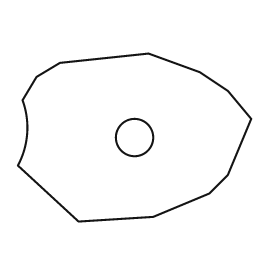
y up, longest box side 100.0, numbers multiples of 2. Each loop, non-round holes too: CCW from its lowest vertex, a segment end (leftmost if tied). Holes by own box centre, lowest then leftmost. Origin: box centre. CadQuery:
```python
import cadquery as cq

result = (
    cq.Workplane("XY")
    .moveTo(-24.0, -36.0)
    .lineTo(8.0, -34.0)
    .lineTo(32.0, -24.0)
    .lineTo(40.0, -16.0)
    .lineTo(50.0, 8.0)
    .lineTo(40.0, 20.0)
    .lineTo(28.0, 28.0)
    .lineTo(6.0, 36.0)
    .lineTo(-32.0, 32.0)
    .lineTo(-42.0, 26.0)
    .lineTo(-48.0, 16.0)
    .threePointArc((-46.0, 2.0), (-50.0, -12.0))
    .close()
    .moveTo(0.0, 0.0)
    .circle(8.0)
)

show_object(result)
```